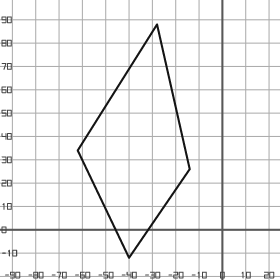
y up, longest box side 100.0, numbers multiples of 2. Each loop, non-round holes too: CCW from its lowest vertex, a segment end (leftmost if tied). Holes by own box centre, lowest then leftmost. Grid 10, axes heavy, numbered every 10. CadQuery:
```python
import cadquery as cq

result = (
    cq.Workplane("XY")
    .moveTo(-40.0, -12.0)
    .lineTo(-14.0, 26.0)
    .lineTo(-28.0, 88.0)
    .lineTo(-62.0, 34.0)
    .close()
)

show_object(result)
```